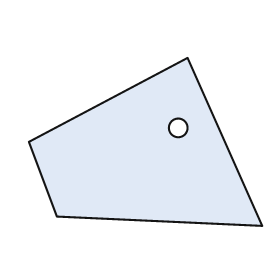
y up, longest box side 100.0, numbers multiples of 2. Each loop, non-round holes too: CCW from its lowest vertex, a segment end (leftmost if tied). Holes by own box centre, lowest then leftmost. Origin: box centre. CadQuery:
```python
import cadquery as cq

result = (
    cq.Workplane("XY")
    .moveTo(50.0, -36.0)
    .lineTo(18.0, 36.0)
    .lineTo(-50.0, 0.0)
    .lineTo(-38.0, -32.0)
    .close()
    .moveTo(14.0, 6.0)
    .circle(4.0)
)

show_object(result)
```